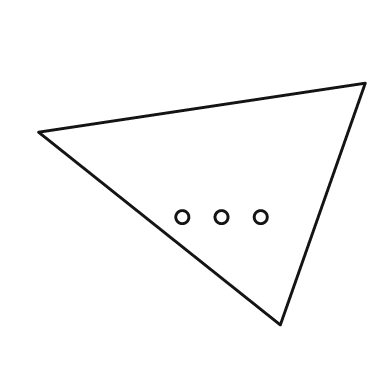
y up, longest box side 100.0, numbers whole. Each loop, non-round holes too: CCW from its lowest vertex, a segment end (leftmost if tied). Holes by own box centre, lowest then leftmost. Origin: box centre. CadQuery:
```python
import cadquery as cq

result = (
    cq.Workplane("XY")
    .moveTo(24.0, -37.0)
    .lineTo(50.0, 37.0)
    .lineTo(-50.0, 22.0)
    .close()
    .moveTo(-6.0, -4.0)
    .circle(2.0)
    .moveTo(6.0, -4.0)
    .circle(2.0)
    .moveTo(18.0, -4.0)
    .circle(2.0)
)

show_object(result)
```